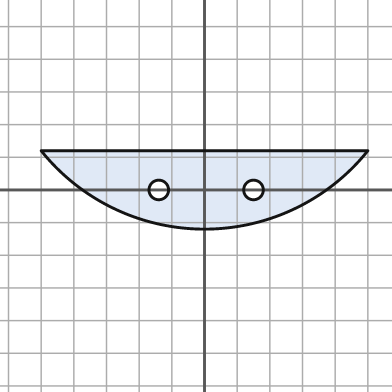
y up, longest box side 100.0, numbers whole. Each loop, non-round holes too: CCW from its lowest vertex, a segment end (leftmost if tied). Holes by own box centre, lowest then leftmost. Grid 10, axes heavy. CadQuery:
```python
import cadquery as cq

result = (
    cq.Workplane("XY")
    .moveTo(-50.0, 12.0)
    .threePointArc((0.0, -12.0), (50.0, 12.0))
    .close()
    .moveTo(-14.0, 0.0)
    .circle(3.0)
    .moveTo(15.0, 0.0)
    .circle(3.0)
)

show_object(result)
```